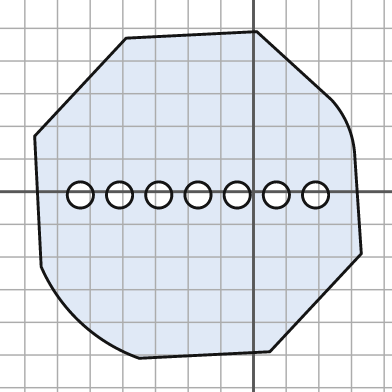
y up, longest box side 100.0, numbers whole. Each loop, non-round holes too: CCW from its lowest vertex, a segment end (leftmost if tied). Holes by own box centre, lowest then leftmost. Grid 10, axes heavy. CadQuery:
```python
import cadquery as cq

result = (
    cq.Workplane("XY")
    .moveTo(-35.0, -51.0)
    .lineTo(5.0, -49.0)
    .lineTo(33.0, -19.0)
    .lineTo(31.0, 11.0)
    .threePointArc((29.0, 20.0), (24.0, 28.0))
    .lineTo(1.0, 49.0)
    .lineTo(-39.0, 47.0)
    .lineTo(-67.0, 17.0)
    .lineTo(-65.0, -23.0)
    .threePointArc((-53.0, -40.0), (-35.0, -51.0))
    .close()
    .moveTo(-53.0, -1.0)
    .circle(4.0)
    .moveTo(-41.0, -1.0)
    .circle(4.0)
    .moveTo(-29.0, -1.0)
    .circle(4.0)
    .moveTo(-17.0, -1.0)
    .circle(4.0)
    .moveTo(-5.0, -1.0)
    .circle(4.0)
    .moveTo(7.0, -1.0)
    .circle(4.0)
    .moveTo(19.0, -1.0)
    .circle(4.0)
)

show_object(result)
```